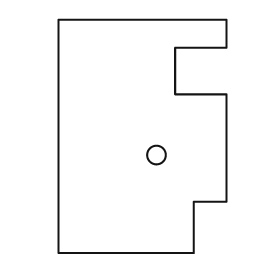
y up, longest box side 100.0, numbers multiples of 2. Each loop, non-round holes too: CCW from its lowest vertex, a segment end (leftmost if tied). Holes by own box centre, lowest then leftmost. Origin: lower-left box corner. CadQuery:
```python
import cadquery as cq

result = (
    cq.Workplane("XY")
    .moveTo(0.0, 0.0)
    .lineTo(58.0, 0.0)
    .lineTo(58.0, 22.0)
    .lineTo(72.0, 22.0)
    .lineTo(72.0, 68.0)
    .lineTo(50.0, 68.0)
    .lineTo(50.0, 88.0)
    .lineTo(72.0, 88.0)
    .lineTo(72.0, 100.0)
    .lineTo(0.0, 100.0)
    .close()
    .moveTo(42.0, 42.0)
    .circle(4.0)
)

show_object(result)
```